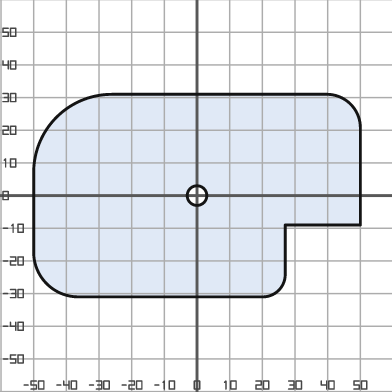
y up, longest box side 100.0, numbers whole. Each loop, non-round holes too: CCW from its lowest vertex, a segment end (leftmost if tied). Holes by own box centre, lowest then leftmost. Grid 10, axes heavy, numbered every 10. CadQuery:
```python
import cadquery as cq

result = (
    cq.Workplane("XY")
    .moveTo(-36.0, -31.0)
    .lineTo(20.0, -31.0)
    .threePointArc((25.0, -29.0), (27.0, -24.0))
    .lineTo(27.0, -9.0)
    .lineTo(50.0, -9.0)
    .lineTo(50.0, 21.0)
    .threePointArc((47.0, 28.0), (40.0, 31.0))
    .lineTo(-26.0, 31.0)
    .threePointArc((-43.0, 24.0), (-50.0, 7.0))
    .lineTo(-50.0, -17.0)
    .threePointArc((-46.0, -27.0), (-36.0, -31.0))
    .close()
    .moveTo(0.0, 0.0)
    .circle(3.0)
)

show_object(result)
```